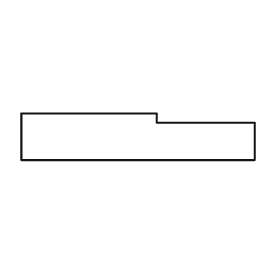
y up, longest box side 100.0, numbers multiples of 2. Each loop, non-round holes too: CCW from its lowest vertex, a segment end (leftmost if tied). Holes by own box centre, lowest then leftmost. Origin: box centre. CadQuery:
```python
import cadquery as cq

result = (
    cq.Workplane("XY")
    .moveTo(-50.0, -10.0)
    .lineTo(50.0, -10.0)
    .lineTo(50.0, 6.0)
    .lineTo(8.0, 6.0)
    .lineTo(8.0, 10.0)
    .lineTo(-50.0, 10.0)
    .close()
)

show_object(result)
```